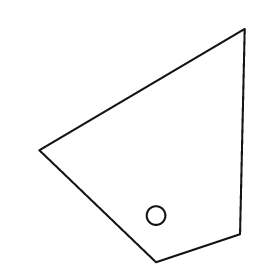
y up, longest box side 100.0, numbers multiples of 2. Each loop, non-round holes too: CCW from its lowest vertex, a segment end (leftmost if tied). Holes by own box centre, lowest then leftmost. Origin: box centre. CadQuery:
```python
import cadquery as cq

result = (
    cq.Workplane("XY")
    .moveTo(6.0, -50.0)
    .lineTo(42.0, -38.0)
    .lineTo(44.0, 50.0)
    .lineTo(-44.0, -2.0)
    .close()
    .moveTo(6.0, -30.0)
    .circle(4.0)
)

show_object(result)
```